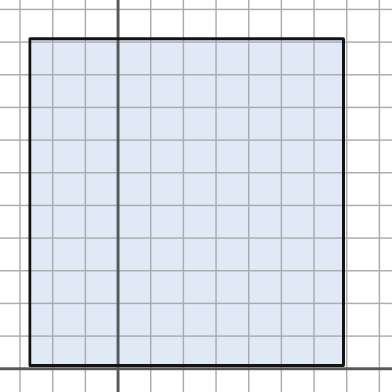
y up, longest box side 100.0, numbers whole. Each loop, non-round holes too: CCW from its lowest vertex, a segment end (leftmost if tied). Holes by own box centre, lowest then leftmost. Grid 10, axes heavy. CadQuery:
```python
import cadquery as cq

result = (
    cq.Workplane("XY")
    .moveTo(-27.0, 1.0)
    .lineTo(69.0, 1.0)
    .lineTo(69.0, 101.0)
    .lineTo(-27.0, 101.0)
    .close()
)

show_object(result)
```